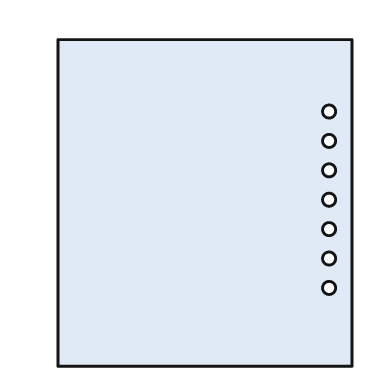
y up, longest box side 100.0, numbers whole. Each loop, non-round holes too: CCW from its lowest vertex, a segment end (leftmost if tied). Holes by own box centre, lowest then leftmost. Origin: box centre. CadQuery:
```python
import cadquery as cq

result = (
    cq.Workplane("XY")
    .moveTo(-45.0, -50.0)
    .lineTo(45.0, -50.0)
    .lineTo(45.0, 50.0)
    .lineTo(-45.0, 50.0)
    .close()
    .moveTo(38.0, -26.0)
    .circle(2.0)
    .moveTo(38.0, -17.0)
    .circle(2.0)
    .moveTo(38.0, -8.0)
    .circle(2.0)
    .moveTo(38.0, 1.0)
    .circle(2.0)
    .moveTo(38.0, 10.0)
    .circle(2.0)
    .moveTo(38.0, 19.0)
    .circle(2.0)
    .moveTo(38.0, 28.0)
    .circle(2.0)
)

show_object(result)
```